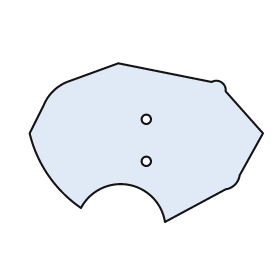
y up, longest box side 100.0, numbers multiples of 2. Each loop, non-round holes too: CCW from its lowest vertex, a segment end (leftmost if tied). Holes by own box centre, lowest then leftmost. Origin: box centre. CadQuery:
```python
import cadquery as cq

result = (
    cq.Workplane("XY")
    .moveTo(8.0, -34.0)
    .lineTo(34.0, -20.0)
    .threePointArc((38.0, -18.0), (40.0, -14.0))
    .lineTo(50.0, 4.0)
    .lineTo(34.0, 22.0)
    .threePointArc((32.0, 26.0), (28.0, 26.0))
    .lineTo(-12.0, 34.0)
    .lineTo(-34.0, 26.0)
    .threePointArc((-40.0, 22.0), (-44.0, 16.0))
    .lineTo(-50.0, 4.0)
    .threePointArc((-42.0, -14.0), (-28.0, -28.0))
    .threePointArc((-8.0, -18.0), (8.0, -34.0))
    .close()
    .moveTo(0.0, -8.0)
    .circle(2.0)
    .moveTo(0.0, 10.0)
    .circle(2.0)
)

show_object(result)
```